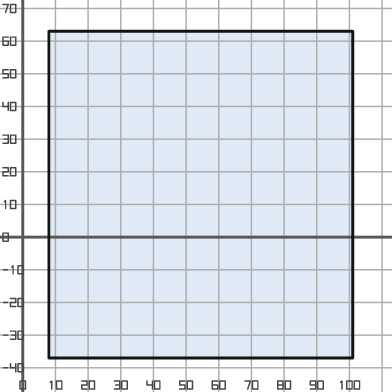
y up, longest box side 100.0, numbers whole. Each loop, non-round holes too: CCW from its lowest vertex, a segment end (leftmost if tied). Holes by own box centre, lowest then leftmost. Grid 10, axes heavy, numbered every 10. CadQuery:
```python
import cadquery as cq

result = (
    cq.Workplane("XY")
    .moveTo(8.0, -37.0)
    .lineTo(101.0, -37.0)
    .lineTo(101.0, 63.0)
    .lineTo(8.0, 63.0)
    .close()
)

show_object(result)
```